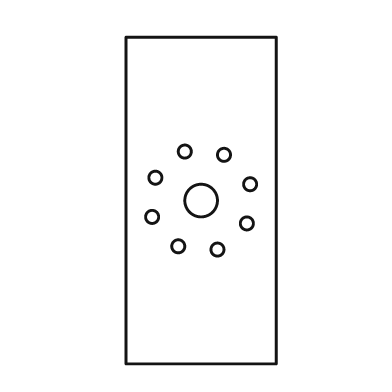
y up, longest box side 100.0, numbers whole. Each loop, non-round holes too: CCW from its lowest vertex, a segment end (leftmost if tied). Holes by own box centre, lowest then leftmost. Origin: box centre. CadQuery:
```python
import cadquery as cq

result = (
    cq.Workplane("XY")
    .moveTo(-23.0, -50.0)
    .lineTo(23.0, -50.0)
    .lineTo(23.0, 50.0)
    .lineTo(-23.0, 50.0)
    .close()
    .moveTo(5.0, -15.0)
    .circle(2.0)
    .moveTo(-7.0, -14.0)
    .circle(2.0)
    .moveTo(14.0, -7.0)
    .circle(2.0)
    .moveTo(-15.0, -5.0)
    .circle(2.0)
    .moveTo(0.0, 0.0)
    .circle(5.0)
    .moveTo(15.0, 5.0)
    .circle(2.0)
    .moveTo(-14.0, 7.0)
    .circle(2.0)
    .moveTo(7.0, 14.0)
    .circle(2.0)
    .moveTo(-5.0, 15.0)
    .circle(2.0)
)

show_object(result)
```